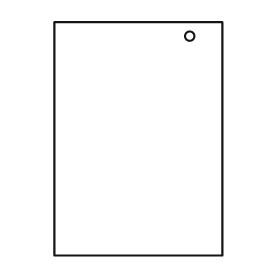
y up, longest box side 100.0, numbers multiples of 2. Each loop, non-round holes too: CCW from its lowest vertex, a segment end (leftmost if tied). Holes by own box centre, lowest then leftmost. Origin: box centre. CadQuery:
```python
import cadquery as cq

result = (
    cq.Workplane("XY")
    .moveTo(-36.0, -50.0)
    .lineTo(36.0, -50.0)
    .lineTo(36.0, 50.0)
    .lineTo(-36.0, 50.0)
    .close()
    .moveTo(22.0, 44.0)
    .circle(2.0)
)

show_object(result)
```